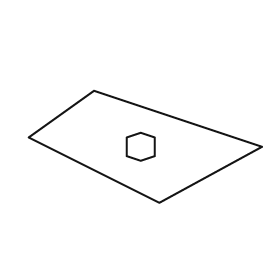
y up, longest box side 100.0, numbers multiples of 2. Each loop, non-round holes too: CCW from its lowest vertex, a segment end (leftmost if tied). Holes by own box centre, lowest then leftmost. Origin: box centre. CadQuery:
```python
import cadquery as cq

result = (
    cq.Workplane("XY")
    .moveTo(6.0, -24.0)
    .lineTo(50.0, 0.0)
    .lineTo(-22.0, 24.0)
    .lineTo(-50.0, 4.0)
    .close()
    .moveTo(-2.0, -6.0)
    .lineTo(4.0, -4.0)
    .lineTo(4.0, 4.0)
    .lineTo(-2.0, 6.0)
    .lineTo(-8.0, 4.0)
    .lineTo(-8.0, -4.0)
    .close()
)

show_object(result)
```